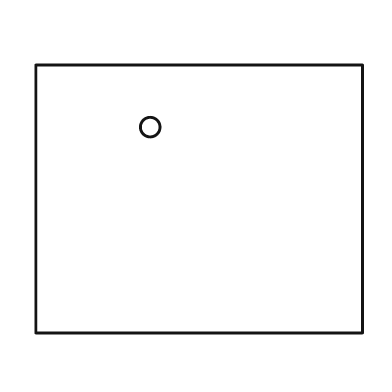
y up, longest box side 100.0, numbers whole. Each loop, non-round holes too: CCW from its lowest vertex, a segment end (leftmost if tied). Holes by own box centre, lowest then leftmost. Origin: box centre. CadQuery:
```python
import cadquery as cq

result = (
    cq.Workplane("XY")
    .moveTo(-50.0, -41.0)
    .lineTo(50.0, -41.0)
    .lineTo(50.0, 41.0)
    .lineTo(-50.0, 41.0)
    .close()
    .moveTo(-15.0, 22.0)
    .circle(3.0)
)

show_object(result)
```